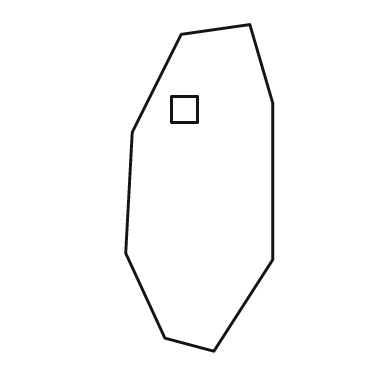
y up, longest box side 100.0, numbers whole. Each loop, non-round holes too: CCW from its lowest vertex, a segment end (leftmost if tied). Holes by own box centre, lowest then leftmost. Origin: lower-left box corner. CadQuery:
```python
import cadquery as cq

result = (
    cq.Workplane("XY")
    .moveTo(27.0, 0.0)
    .lineTo(45.0, 28.0)
    .lineTo(45.0, 76.0)
    .lineTo(38.0, 100.0)
    .lineTo(17.0, 97.0)
    .lineTo(2.0, 67.0)
    .lineTo(0.0, 30.0)
    .lineTo(12.0, 4.0)
    .close()
    .moveTo(14.0, 70.0)
    .lineTo(22.0, 70.0)
    .lineTo(22.0, 78.0)
    .lineTo(14.0, 78.0)
    .close()
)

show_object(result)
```